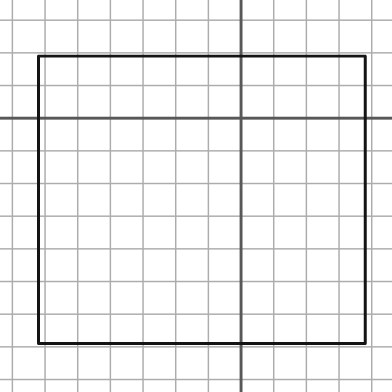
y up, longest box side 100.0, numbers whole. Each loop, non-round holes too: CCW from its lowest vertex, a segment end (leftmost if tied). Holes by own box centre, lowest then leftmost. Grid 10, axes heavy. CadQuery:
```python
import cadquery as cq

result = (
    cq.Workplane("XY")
    .moveTo(-62.0, -69.0)
    .lineTo(38.0, -69.0)
    .lineTo(38.0, 19.0)
    .lineTo(-62.0, 19.0)
    .close()
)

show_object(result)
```